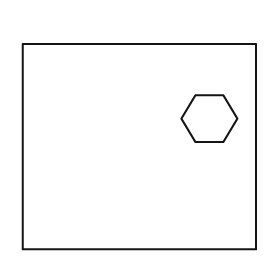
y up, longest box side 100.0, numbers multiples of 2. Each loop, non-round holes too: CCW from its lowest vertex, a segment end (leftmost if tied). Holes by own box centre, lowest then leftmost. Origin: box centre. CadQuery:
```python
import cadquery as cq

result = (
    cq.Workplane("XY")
    .moveTo(-50.0, -44.0)
    .lineTo(50.0, -44.0)
    .lineTo(50.0, 44.0)
    .lineTo(-50.0, 44.0)
    .close()
    .moveTo(24.0, 2.0)
    .lineTo(36.0, 2.0)
    .lineTo(42.0, 12.0)
    .lineTo(36.0, 22.0)
    .lineTo(24.0, 22.0)
    .lineTo(18.0, 12.0)
    .close()
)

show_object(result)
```